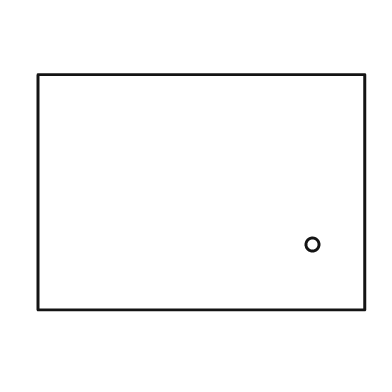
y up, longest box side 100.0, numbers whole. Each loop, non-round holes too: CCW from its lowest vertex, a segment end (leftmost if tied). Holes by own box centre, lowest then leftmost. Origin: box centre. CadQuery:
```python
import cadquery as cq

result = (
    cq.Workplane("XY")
    .moveTo(-50.0, -36.0)
    .lineTo(50.0, -36.0)
    .lineTo(50.0, 36.0)
    .lineTo(-50.0, 36.0)
    .close()
    .moveTo(34.0, -16.0)
    .circle(2.0)
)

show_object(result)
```